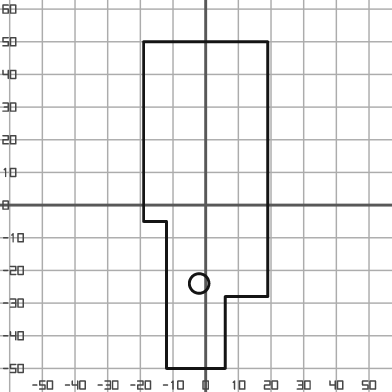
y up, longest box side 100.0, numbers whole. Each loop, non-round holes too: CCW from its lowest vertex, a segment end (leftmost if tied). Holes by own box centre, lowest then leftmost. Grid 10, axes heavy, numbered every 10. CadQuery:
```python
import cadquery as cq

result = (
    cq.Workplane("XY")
    .moveTo(-12.0, -50.0)
    .lineTo(6.0, -50.0)
    .lineTo(6.0, -28.0)
    .lineTo(19.0, -28.0)
    .lineTo(19.0, 50.0)
    .lineTo(-19.0, 50.0)
    .lineTo(-19.0, -5.0)
    .lineTo(-12.0, -5.0)
    .close()
    .moveTo(-2.0, -24.0)
    .circle(3.0)
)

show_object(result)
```